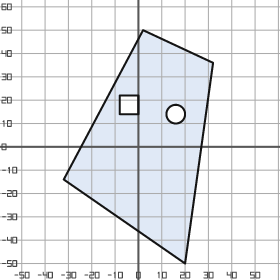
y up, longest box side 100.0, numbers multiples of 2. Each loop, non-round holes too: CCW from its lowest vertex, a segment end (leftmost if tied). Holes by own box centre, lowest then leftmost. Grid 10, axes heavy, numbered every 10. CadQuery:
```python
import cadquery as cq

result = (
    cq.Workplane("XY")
    .moveTo(20.0, -50.0)
    .lineTo(32.0, 36.0)
    .lineTo(2.0, 50.0)
    .lineTo(-32.0, -14.0)
    .close()
    .moveTo(16.0, 14.0)
    .circle(4.0)
    .moveTo(-8.0, 14.0)
    .lineTo(0.0, 14.0)
    .lineTo(0.0, 22.0)
    .lineTo(-8.0, 22.0)
    .close()
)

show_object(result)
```